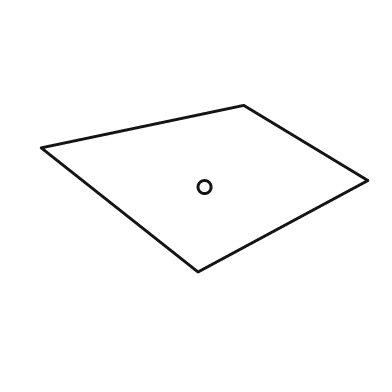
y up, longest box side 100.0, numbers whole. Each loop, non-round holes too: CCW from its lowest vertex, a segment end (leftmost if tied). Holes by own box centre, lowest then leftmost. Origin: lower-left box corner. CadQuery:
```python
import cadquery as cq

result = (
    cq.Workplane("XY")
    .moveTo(48.0, 0.0)
    .lineTo(100.0, 28.0)
    .lineTo(62.0, 51.0)
    .lineTo(0.0, 38.0)
    .close()
    .moveTo(50.0, 26.0)
    .circle(2.0)
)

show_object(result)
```